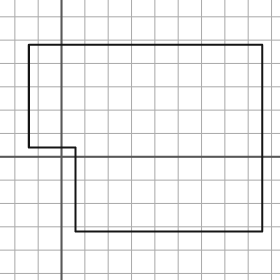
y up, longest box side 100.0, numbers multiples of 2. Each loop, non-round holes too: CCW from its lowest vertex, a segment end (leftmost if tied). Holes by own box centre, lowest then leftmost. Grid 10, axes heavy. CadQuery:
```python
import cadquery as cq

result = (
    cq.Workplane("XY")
    .moveTo(6.0, -32.0)
    .lineTo(86.0, -32.0)
    .lineTo(86.0, 48.0)
    .lineTo(-14.0, 48.0)
    .lineTo(-14.0, 4.0)
    .lineTo(6.0, 4.0)
    .close()
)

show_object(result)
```